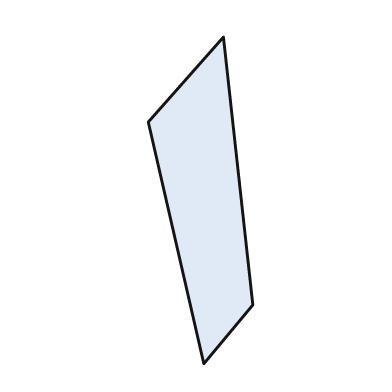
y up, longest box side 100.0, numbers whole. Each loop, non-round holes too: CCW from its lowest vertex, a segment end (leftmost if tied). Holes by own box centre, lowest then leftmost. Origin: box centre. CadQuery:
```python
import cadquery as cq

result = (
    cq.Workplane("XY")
    .moveTo(1.0, -50.0)
    .lineTo(16.0, -32.0)
    .lineTo(7.0, 50.0)
    .lineTo(-16.0, 24.0)
    .close()
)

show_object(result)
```